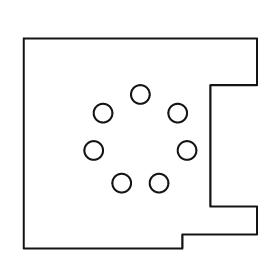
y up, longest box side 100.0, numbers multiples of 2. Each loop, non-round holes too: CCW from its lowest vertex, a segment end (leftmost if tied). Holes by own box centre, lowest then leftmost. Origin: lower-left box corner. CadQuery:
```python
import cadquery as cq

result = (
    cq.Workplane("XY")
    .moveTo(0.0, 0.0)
    .lineTo(68.0, 0.0)
    .lineTo(68.0, 6.0)
    .lineTo(100.0, 6.0)
    .lineTo(100.0, 18.0)
    .lineTo(80.0, 18.0)
    .lineTo(80.0, 70.0)
    .lineTo(100.0, 70.0)
    .lineTo(100.0, 90.0)
    .lineTo(0.0, 90.0)
    .close()
    .moveTo(42.0, 28.0)
    .circle(4.0)
    .moveTo(58.0, 28.0)
    .circle(4.0)
    .moveTo(30.0, 42.0)
    .circle(4.0)
    .moveTo(70.0, 42.0)
    .circle(4.0)
    .moveTo(34.0, 58.0)
    .circle(4.0)
    .moveTo(66.0, 58.0)
    .circle(4.0)
    .moveTo(50.0, 66.0)
    .circle(4.0)
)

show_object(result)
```